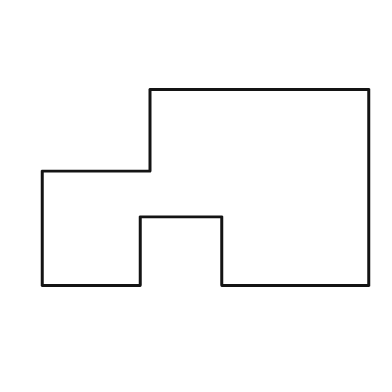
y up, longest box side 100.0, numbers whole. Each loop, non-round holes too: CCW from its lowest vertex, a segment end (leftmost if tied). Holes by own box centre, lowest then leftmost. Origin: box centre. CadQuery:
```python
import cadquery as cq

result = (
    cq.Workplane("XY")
    .moveTo(-50.0, -30.0)
    .lineTo(-20.0, -30.0)
    .lineTo(-20.0, -9.0)
    .lineTo(5.0, -9.0)
    .lineTo(5.0, -30.0)
    .lineTo(50.0, -30.0)
    .lineTo(50.0, 30.0)
    .lineTo(-17.0, 30.0)
    .lineTo(-17.0, 5.0)
    .lineTo(-50.0, 5.0)
    .close()
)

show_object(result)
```